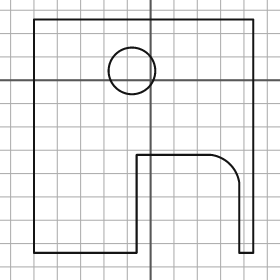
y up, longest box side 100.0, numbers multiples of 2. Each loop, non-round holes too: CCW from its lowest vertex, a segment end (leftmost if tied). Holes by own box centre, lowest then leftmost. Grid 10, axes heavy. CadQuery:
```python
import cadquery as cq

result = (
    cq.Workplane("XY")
    .moveTo(-50.0, -74.0)
    .lineTo(-6.0, -74.0)
    .lineTo(-6.0, -32.0)
    .lineTo(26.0, -32.0)
    .threePointArc((34.0, -36.0), (38.0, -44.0))
    .lineTo(38.0, -74.0)
    .lineTo(44.0, -74.0)
    .lineTo(44.0, 26.0)
    .lineTo(-50.0, 26.0)
    .close()
    .moveTo(-8.0, 4.0)
    .circle(10.0)
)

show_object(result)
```